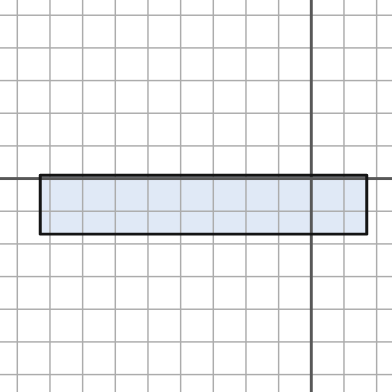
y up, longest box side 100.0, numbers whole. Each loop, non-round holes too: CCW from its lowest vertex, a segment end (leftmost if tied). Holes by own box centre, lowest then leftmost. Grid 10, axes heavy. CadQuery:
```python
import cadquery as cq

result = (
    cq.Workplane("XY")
    .moveTo(-83.0, -17.0)
    .lineTo(17.0, -17.0)
    .lineTo(17.0, 1.0)
    .lineTo(-83.0, 1.0)
    .close()
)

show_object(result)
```